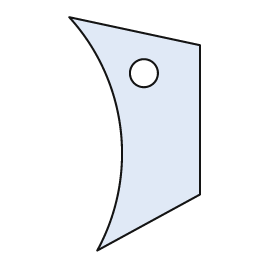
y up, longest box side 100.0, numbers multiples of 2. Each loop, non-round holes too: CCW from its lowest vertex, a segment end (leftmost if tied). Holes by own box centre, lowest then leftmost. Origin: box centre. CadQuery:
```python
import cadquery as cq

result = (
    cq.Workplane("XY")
    .moveTo(-16.0, -50.0)
    .lineTo(28.0, -26.0)
    .lineTo(28.0, 38.0)
    .lineTo(-28.0, 50.0)
    .threePointArc((-6.0, 2.0), (-16.0, -50.0))
    .close()
    .moveTo(4.0, 26.0)
    .circle(6.0)
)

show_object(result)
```